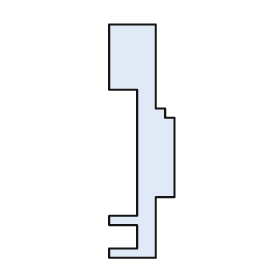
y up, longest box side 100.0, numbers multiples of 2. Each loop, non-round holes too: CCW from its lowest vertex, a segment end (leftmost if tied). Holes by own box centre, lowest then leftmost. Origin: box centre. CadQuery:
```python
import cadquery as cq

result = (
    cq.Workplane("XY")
    .moveTo(-14.0, -50.0)
    .lineTo(6.0, -50.0)
    .lineTo(6.0, -24.0)
    .lineTo(14.0, -24.0)
    .lineTo(14.0, 10.0)
    .lineTo(10.0, 10.0)
    .lineTo(10.0, 14.0)
    .lineTo(6.0, 14.0)
    .lineTo(6.0, 50.0)
    .lineTo(-14.0, 50.0)
    .lineTo(-14.0, 22.0)
    .lineTo(-2.0, 22.0)
    .lineTo(-2.0, -32.0)
    .lineTo(-14.0, -32.0)
    .lineTo(-14.0, -36.0)
    .lineTo(-2.0, -36.0)
    .lineTo(-2.0, -46.0)
    .lineTo(-14.0, -46.0)
    .close()
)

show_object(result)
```